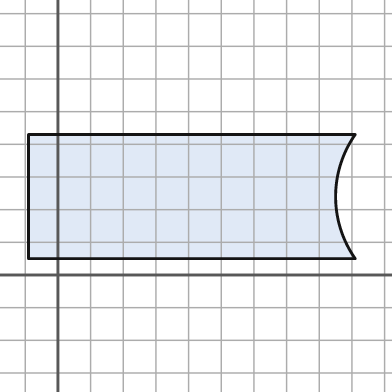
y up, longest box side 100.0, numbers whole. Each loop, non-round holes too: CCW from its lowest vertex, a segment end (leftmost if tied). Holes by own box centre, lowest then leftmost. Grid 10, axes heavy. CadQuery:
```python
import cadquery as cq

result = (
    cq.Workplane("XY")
    .moveTo(-9.0, 5.0)
    .lineTo(91.0, 5.0)
    .threePointArc((85.0, 24.0), (91.0, 43.0))
    .lineTo(-9.0, 43.0)
    .close()
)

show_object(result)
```